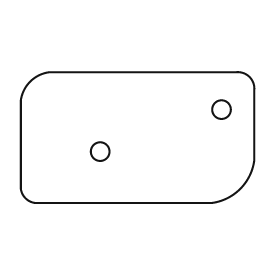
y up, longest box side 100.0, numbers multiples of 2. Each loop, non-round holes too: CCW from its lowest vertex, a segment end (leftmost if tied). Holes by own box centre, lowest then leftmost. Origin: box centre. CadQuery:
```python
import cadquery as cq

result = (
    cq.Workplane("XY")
    .moveTo(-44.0, -28.0)
    .lineTo(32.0, -28.0)
    .threePointArc((44.0, -22.0), (50.0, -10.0))
    .lineTo(50.0, 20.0)
    .threePointArc((48.0, 26.0), (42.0, 28.0))
    .lineTo(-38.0, 28.0)
    .threePointArc((-46.0, 24.0), (-50.0, 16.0))
    .lineTo(-50.0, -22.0)
    .threePointArc((-48.0, -26.0), (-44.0, -28.0))
    .close()
    .moveTo(-16.0, -6.0)
    .circle(4.0)
    .moveTo(36.0, 12.0)
    .circle(4.0)
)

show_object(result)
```